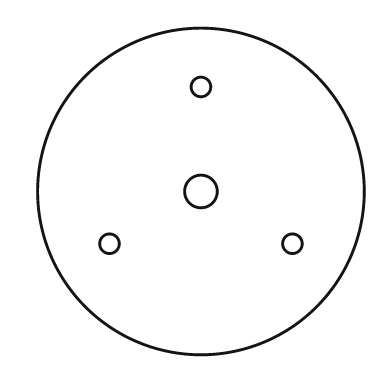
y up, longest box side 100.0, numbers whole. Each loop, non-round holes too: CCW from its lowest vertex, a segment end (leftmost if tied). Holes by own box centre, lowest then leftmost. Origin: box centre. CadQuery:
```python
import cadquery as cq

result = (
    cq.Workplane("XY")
    .moveTo(0.0, 0.0)
    .circle(50.0)
    .moveTo(-28.0, -16.0)
    .circle(3.0)
    .moveTo(28.0, -16.0)
    .circle(3.0)
    .moveTo(0.0, 0.0)
    .circle(5.0)
    .moveTo(0.0, 32.0)
    .circle(3.0)
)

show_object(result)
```